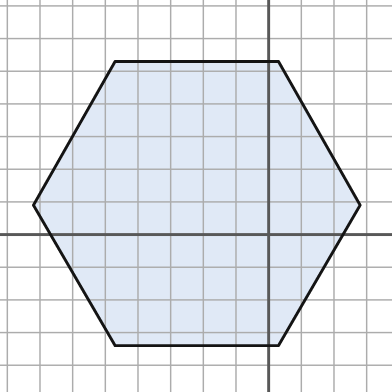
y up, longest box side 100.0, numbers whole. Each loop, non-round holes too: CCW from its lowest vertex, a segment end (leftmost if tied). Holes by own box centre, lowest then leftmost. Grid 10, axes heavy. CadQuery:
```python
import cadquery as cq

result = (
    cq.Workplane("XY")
    .moveTo(-47.0, -34.0)
    .lineTo(3.0, -34.0)
    .lineTo(28.0, 9.0)
    .lineTo(3.0, 53.0)
    .lineTo(-47.0, 53.0)
    .lineTo(-72.0, 9.0)
    .close()
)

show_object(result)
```